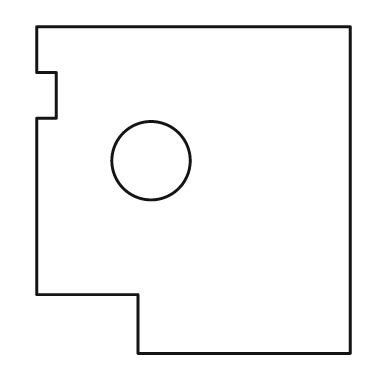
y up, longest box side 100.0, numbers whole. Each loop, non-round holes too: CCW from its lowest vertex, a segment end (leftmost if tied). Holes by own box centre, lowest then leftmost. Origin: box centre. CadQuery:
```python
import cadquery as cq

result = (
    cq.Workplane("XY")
    .moveTo(-17.0, -50.0)
    .lineTo(48.0, -50.0)
    .lineTo(48.0, 50.0)
    .lineTo(-48.0, 50.0)
    .lineTo(-48.0, 36.0)
    .lineTo(-42.0, 36.0)
    .lineTo(-42.0, 22.0)
    .lineTo(-48.0, 22.0)
    .lineTo(-48.0, -32.0)
    .lineTo(-17.0, -32.0)
    .close()
    .moveTo(-13.0, 9.0)
    .circle(12.0)
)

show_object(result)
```